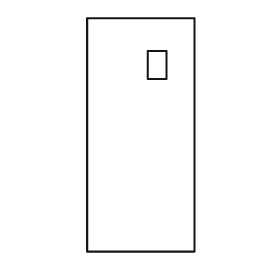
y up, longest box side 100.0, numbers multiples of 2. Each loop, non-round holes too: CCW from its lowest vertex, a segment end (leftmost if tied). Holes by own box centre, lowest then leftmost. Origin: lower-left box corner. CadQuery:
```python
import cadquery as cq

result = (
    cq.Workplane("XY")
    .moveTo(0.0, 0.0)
    .lineTo(46.0, 0.0)
    .lineTo(46.0, 100.0)
    .lineTo(0.0, 100.0)
    .close()
    .moveTo(26.0, 74.0)
    .lineTo(34.0, 74.0)
    .lineTo(34.0, 86.0)
    .lineTo(26.0, 86.0)
    .close()
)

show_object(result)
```